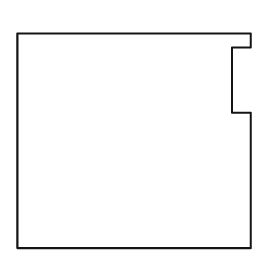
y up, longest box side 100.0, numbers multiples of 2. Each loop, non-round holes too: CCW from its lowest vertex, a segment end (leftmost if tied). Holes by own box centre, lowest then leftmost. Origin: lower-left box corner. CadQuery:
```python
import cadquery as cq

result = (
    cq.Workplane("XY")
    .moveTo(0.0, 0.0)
    .lineTo(100.0, 0.0)
    .lineTo(100.0, 58.0)
    .lineTo(92.0, 58.0)
    .lineTo(92.0, 86.0)
    .lineTo(100.0, 86.0)
    .lineTo(100.0, 92.0)
    .lineTo(0.0, 92.0)
    .close()
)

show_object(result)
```